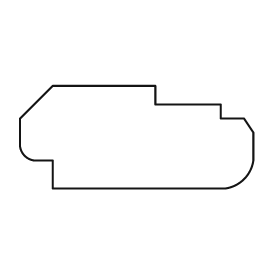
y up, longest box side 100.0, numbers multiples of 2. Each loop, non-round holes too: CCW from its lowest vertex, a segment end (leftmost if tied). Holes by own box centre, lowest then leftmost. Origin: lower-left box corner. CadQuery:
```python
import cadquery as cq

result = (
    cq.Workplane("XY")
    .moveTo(14.0, 0.0)
    .lineTo(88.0, 0.0)
    .threePointArc((96.0, 4.0), (100.0, 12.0))
    .lineTo(100.0, 24.0)
    .lineTo(96.0, 30.0)
    .lineTo(86.0, 30.0)
    .lineTo(86.0, 36.0)
    .lineTo(58.0, 36.0)
    .lineTo(58.0, 44.0)
    .lineTo(14.0, 44.0)
    .lineTo(0.0, 30.0)
    .lineTo(0.0, 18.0)
    .threePointArc((2.0, 14.0), (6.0, 12.0))
    .lineTo(14.0, 12.0)
    .close()
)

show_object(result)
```